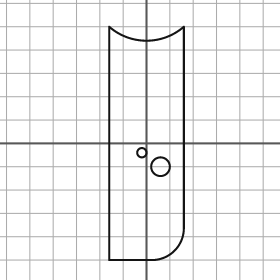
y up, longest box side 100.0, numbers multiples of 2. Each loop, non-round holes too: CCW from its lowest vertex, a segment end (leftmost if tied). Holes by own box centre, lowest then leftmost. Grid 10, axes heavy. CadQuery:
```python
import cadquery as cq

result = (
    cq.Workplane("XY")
    .moveTo(-16.0, -50.0)
    .lineTo(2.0, -50.0)
    .threePointArc((12.0, -46.0), (16.0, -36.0))
    .lineTo(16.0, 50.0)
    .threePointArc((0.0, 44.0), (-16.0, 50.0))
    .close()
    .moveTo(6.0, -10.0)
    .circle(4.0)
    .moveTo(-2.0, -4.0)
    .circle(2.0)
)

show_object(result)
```